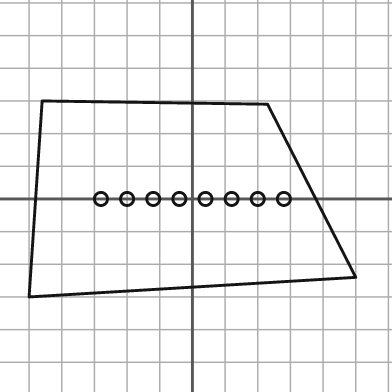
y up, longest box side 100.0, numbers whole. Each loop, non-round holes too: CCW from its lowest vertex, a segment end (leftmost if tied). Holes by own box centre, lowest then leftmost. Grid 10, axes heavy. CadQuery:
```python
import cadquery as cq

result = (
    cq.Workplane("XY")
    .moveTo(-50.0, -30.0)
    .lineTo(50.0, -24.0)
    .lineTo(23.0, 29.0)
    .lineTo(-46.0, 30.0)
    .close()
    .moveTo(-28.0, 0.0)
    .circle(2.0)
    .moveTo(-20.0, 0.0)
    .circle(2.0)
    .moveTo(-12.0, 0.0)
    .circle(2.0)
    .moveTo(-4.0, 0.0)
    .circle(2.0)
    .moveTo(4.0, 0.0)
    .circle(2.0)
    .moveTo(12.0, 0.0)
    .circle(2.0)
    .moveTo(20.0, 0.0)
    .circle(2.0)
    .moveTo(28.0, 0.0)
    .circle(2.0)
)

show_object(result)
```